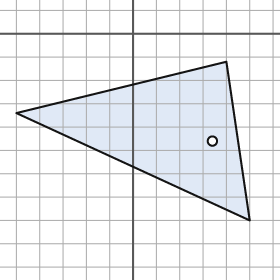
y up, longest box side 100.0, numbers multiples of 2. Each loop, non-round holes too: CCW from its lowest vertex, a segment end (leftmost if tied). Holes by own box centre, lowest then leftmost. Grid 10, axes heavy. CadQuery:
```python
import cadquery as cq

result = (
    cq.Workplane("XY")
    .moveTo(50.0, -80.0)
    .lineTo(40.0, -12.0)
    .lineTo(-50.0, -34.0)
    .close()
    .moveTo(34.0, -46.0)
    .circle(2.0)
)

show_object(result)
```